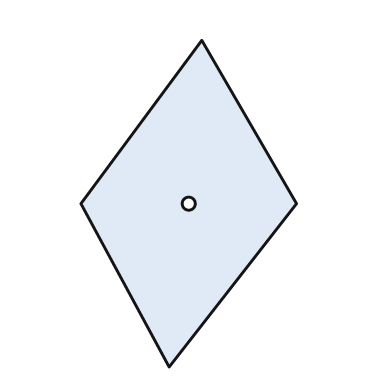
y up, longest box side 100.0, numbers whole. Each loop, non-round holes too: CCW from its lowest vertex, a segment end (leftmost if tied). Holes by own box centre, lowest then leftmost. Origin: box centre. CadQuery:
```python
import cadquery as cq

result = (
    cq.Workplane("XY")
    .moveTo(-6.0, -50.0)
    .lineTo(33.0, 0.0)
    .lineTo(4.0, 50.0)
    .lineTo(-33.0, 0.0)
    .close()
    .moveTo(0.0, 0.0)
    .circle(2.0)
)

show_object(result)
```